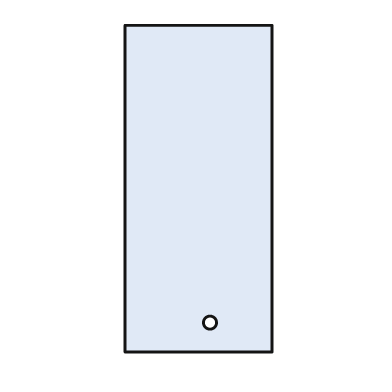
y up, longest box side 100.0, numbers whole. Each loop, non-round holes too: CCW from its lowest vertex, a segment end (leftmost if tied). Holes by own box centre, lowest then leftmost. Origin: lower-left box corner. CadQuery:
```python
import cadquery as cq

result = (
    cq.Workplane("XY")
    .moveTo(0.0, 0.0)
    .lineTo(45.0, 0.0)
    .lineTo(45.0, 100.0)
    .lineTo(0.0, 100.0)
    .close()
    .moveTo(26.0, 9.0)
    .circle(2.0)
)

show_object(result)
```